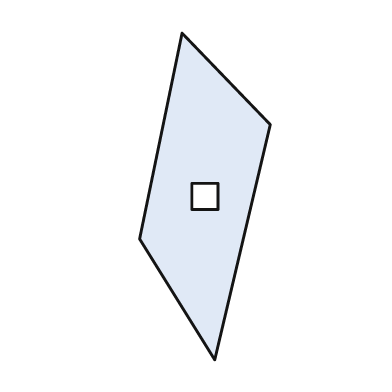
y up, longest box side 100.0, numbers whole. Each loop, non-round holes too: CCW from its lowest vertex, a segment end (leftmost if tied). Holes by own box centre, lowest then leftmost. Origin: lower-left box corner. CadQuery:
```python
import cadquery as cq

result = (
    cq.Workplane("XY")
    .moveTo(23.0, 0.0)
    .lineTo(40.0, 72.0)
    .lineTo(13.0, 100.0)
    .lineTo(0.0, 37.0)
    .close()
    .moveTo(16.0, 46.0)
    .lineTo(24.0, 46.0)
    .lineTo(24.0, 54.0)
    .lineTo(16.0, 54.0)
    .close()
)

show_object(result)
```